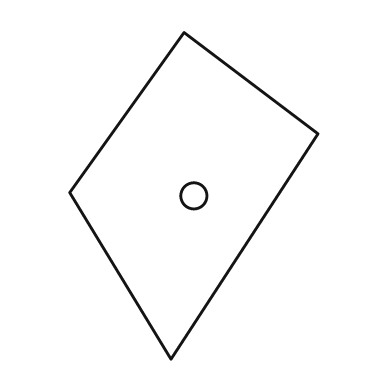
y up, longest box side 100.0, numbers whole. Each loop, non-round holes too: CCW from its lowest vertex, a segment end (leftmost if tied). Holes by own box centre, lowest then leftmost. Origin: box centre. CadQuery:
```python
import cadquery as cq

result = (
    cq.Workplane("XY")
    .moveTo(-7.0, -50.0)
    .lineTo(38.0, 19.0)
    .lineTo(-3.0, 50.0)
    .lineTo(-38.0, 1.0)
    .close()
    .moveTo(0.0, 0.0)
    .circle(4.0)
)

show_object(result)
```